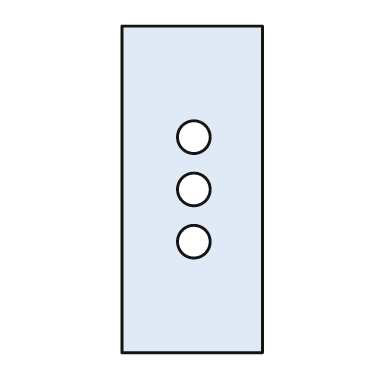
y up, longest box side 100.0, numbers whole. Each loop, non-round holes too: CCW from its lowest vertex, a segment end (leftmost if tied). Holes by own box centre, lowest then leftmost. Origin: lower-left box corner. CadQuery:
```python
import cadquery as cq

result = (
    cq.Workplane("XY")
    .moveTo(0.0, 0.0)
    .lineTo(43.0, 0.0)
    .lineTo(43.0, 100.0)
    .lineTo(0.0, 100.0)
    .close()
    .moveTo(22.0, 34.0)
    .circle(5.0)
    .moveTo(22.0, 50.0)
    .circle(5.0)
    .moveTo(22.0, 66.0)
    .circle(5.0)
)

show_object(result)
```